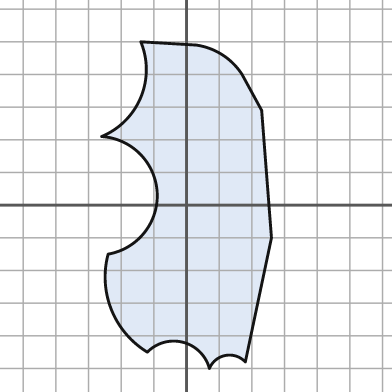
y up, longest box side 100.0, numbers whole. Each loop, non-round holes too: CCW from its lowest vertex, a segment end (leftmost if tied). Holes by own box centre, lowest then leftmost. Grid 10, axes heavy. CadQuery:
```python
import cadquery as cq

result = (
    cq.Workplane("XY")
    .moveTo(7.0, -50.0)
    .threePointArc((12.0, -46.0), (18.0, -48.0))
    .lineTo(26.0, -10.0)
    .lineTo(23.0, 29.0)
    .lineTo(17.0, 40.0)
    .threePointArc((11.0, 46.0), (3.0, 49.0))
    .lineTo(-14.0, 50.0)
    .threePointArc((-14.0, 33.0), (-26.0, 21.0))
    .threePointArc((-9.0, 4.0), (-24.0, -15.0))
    .threePointArc((-23.0, -32.0), (-12.0, -45.0))
    .threePointArc((-1.0, -42.0), (7.0, -50.0))
    .close()
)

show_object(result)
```